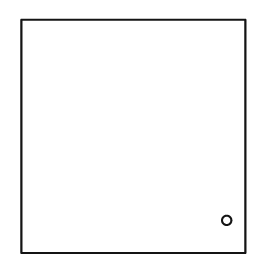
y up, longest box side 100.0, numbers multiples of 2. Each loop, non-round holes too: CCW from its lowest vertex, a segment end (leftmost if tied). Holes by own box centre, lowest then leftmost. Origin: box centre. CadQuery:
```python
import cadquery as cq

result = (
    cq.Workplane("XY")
    .moveTo(-48.0, -50.0)
    .lineTo(48.0, -50.0)
    .lineTo(48.0, 50.0)
    .lineTo(-48.0, 50.0)
    .close()
    .moveTo(40.0, -36.0)
    .circle(2.0)
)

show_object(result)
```